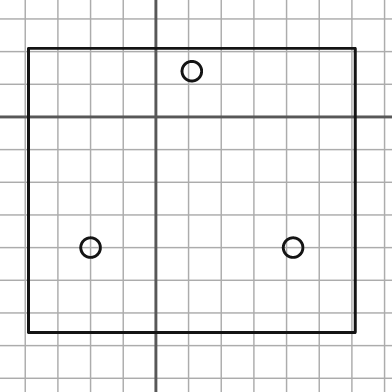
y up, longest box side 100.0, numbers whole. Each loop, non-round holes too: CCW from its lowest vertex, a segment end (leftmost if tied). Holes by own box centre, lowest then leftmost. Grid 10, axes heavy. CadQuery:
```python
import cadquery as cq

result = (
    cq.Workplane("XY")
    .moveTo(-39.0, -66.0)
    .lineTo(61.0, -66.0)
    .lineTo(61.0, 21.0)
    .lineTo(-39.0, 21.0)
    .close()
    .moveTo(-20.0, -40.0)
    .circle(3.0)
    .moveTo(42.0, -40.0)
    .circle(3.0)
    .moveTo(11.0, 14.0)
    .circle(3.0)
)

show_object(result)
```